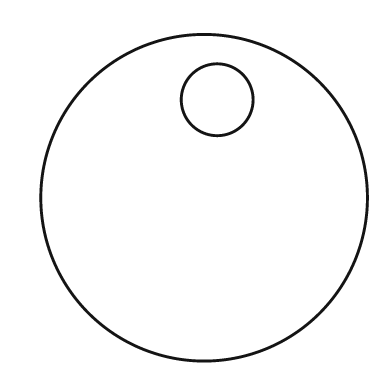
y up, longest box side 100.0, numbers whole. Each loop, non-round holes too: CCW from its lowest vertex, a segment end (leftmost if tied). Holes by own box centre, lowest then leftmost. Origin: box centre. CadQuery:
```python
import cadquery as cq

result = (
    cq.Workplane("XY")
    .moveTo(0.0, 0.0)
    .circle(50.0)
    .moveTo(4.0, 30.0)
    .circle(11.0)
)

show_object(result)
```